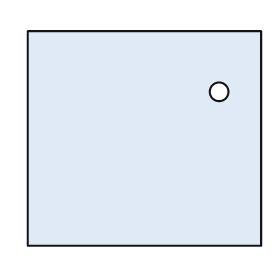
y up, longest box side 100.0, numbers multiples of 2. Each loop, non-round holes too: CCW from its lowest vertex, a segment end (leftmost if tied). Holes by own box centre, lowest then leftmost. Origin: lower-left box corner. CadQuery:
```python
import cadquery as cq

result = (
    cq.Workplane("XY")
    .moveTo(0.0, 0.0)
    .lineTo(100.0, 0.0)
    .lineTo(100.0, 92.0)
    .lineTo(0.0, 92.0)
    .close()
    .moveTo(82.0, 66.0)
    .circle(4.0)
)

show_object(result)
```